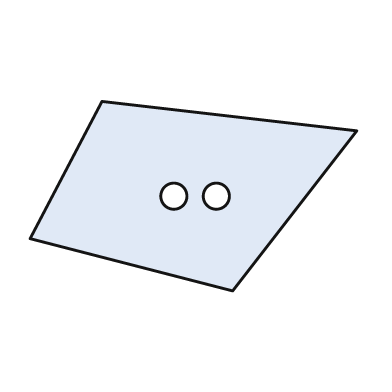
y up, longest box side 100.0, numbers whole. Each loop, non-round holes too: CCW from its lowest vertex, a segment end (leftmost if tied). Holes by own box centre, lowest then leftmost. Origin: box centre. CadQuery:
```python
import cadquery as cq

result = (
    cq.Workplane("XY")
    .moveTo(12.0, -29.0)
    .lineTo(50.0, 20.0)
    .lineTo(-28.0, 29.0)
    .lineTo(-50.0, -13.0)
    .close()
    .moveTo(-6.0, 0.0)
    .circle(4.0)
    .moveTo(7.0, 0.0)
    .circle(4.0)
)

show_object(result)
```